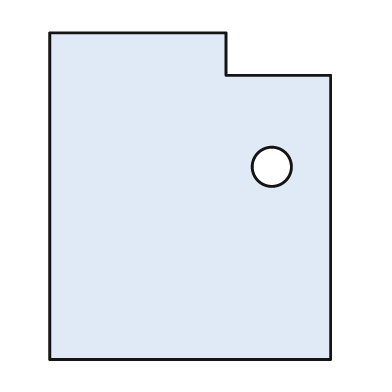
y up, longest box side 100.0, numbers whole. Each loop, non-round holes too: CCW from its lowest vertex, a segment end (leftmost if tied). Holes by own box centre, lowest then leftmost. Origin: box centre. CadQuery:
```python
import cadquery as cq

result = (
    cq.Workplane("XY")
    .moveTo(-43.0, -50.0)
    .lineTo(43.0, -50.0)
    .lineTo(43.0, 37.0)
    .lineTo(11.0, 37.0)
    .lineTo(11.0, 50.0)
    .lineTo(-43.0, 50.0)
    .close()
    .moveTo(25.0, 9.0)
    .circle(6.0)
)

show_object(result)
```